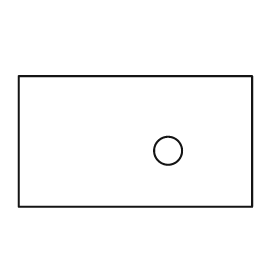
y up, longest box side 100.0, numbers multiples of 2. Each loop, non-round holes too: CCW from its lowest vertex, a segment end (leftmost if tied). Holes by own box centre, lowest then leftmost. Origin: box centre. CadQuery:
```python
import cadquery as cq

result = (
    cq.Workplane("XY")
    .moveTo(-50.0, -28.0)
    .lineTo(50.0, -28.0)
    .lineTo(50.0, 28.0)
    .lineTo(-50.0, 28.0)
    .close()
    .moveTo(14.0, -4.0)
    .circle(6.0)
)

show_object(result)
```